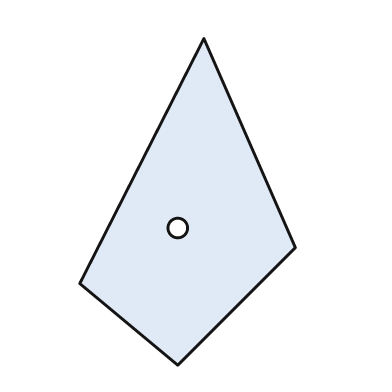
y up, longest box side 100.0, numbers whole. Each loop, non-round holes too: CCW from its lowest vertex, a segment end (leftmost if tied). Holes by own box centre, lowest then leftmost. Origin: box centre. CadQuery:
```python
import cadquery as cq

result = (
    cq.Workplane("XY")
    .moveTo(-3.0, -50.0)
    .lineTo(33.0, -14.0)
    .lineTo(5.0, 50.0)
    .lineTo(-33.0, -25.0)
    .close()
    .moveTo(-3.0, -8.0)
    .circle(3.0)
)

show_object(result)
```